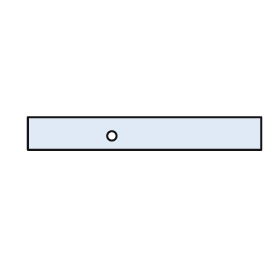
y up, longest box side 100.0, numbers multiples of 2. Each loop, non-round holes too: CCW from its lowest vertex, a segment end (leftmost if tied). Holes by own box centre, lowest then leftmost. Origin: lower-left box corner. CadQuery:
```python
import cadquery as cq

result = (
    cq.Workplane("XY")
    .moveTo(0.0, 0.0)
    .lineTo(100.0, 0.0)
    .lineTo(100.0, 14.0)
    .lineTo(0.0, 14.0)
    .close()
    .moveTo(36.0, 6.0)
    .circle(2.0)
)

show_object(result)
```